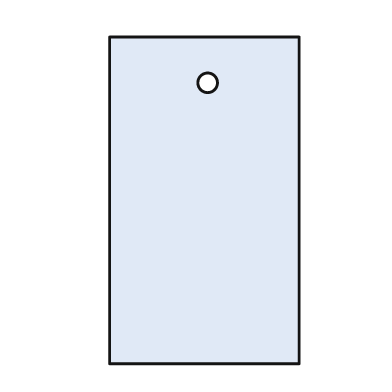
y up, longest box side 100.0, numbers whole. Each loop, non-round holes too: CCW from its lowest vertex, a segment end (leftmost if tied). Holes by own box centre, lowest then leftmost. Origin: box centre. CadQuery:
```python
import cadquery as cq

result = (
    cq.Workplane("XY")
    .moveTo(-29.0, -50.0)
    .lineTo(29.0, -50.0)
    .lineTo(29.0, 50.0)
    .lineTo(-29.0, 50.0)
    .close()
    .moveTo(1.0, 36.0)
    .circle(3.0)
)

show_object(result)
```